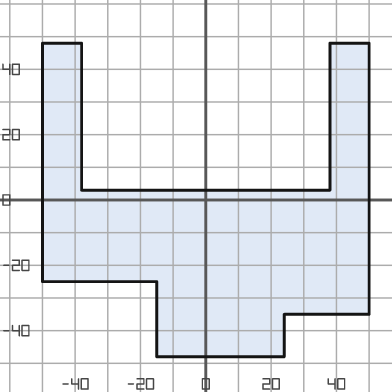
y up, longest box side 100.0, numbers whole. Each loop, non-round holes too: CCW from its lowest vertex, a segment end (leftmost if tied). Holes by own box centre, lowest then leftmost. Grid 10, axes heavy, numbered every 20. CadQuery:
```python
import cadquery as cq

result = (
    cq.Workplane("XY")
    .moveTo(-15.0, -48.0)
    .lineTo(24.0, -48.0)
    .lineTo(24.0, -35.0)
    .lineTo(50.0, -35.0)
    .lineTo(50.0, 48.0)
    .lineTo(38.0, 48.0)
    .lineTo(38.0, 3.0)
    .lineTo(-38.0, 3.0)
    .lineTo(-38.0, 48.0)
    .lineTo(-50.0, 48.0)
    .lineTo(-50.0, -25.0)
    .lineTo(-15.0, -25.0)
    .close()
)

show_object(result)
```